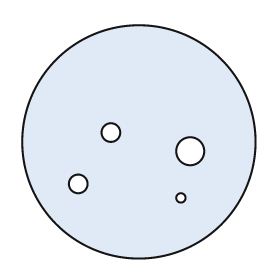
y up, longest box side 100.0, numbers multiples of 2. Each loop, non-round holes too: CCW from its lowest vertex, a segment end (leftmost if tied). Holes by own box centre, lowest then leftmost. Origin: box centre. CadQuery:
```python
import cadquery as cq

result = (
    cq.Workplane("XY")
    .moveTo(0.0, 0.0)
    .circle(50.0)
    .moveTo(18.0, -24.0)
    .circle(2.0)
    .moveTo(-26.0, -18.0)
    .circle(4.0)
    .moveTo(22.0, -4.0)
    .circle(6.0)
    .moveTo(-12.0, 4.0)
    .circle(4.0)
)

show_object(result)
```